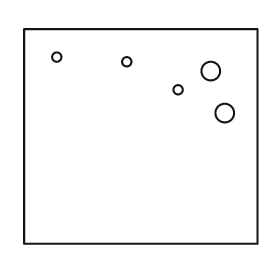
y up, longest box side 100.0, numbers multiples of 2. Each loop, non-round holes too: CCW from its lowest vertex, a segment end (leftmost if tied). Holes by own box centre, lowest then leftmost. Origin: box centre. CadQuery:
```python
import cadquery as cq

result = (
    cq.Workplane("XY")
    .moveTo(-50.0, -46.0)
    .lineTo(50.0, -46.0)
    .lineTo(50.0, 46.0)
    .lineTo(-50.0, 46.0)
    .close()
    .moveTo(36.0, 10.0)
    .circle(4.0)
    .moveTo(16.0, 20.0)
    .circle(2.0)
    .moveTo(30.0, 28.0)
    .circle(4.0)
    .moveTo(-6.0, 32.0)
    .circle(2.0)
    .moveTo(-36.0, 34.0)
    .circle(2.0)
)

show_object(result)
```